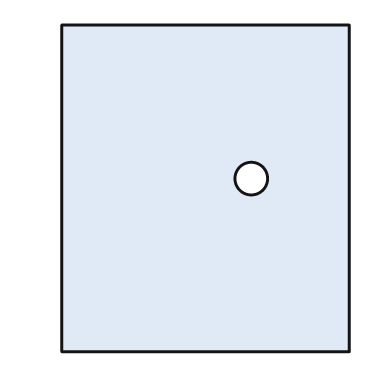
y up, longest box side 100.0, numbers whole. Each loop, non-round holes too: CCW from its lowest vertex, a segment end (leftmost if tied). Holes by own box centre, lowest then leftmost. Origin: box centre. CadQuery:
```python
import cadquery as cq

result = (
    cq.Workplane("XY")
    .moveTo(-44.0, -50.0)
    .lineTo(44.0, -50.0)
    .lineTo(44.0, 50.0)
    .lineTo(-44.0, 50.0)
    .close()
    .moveTo(14.0, 3.0)
    .circle(5.0)
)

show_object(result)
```